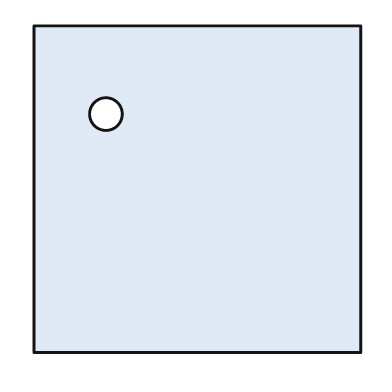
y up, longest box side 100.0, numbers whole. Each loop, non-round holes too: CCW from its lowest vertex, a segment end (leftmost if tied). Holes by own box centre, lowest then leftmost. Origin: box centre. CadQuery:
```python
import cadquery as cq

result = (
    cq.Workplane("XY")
    .moveTo(-50.0, -50.0)
    .lineTo(50.0, -50.0)
    .lineTo(50.0, 50.0)
    .lineTo(-50.0, 50.0)
    .close()
    .moveTo(-28.0, 23.0)
    .circle(5.0)
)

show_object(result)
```